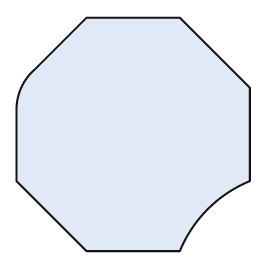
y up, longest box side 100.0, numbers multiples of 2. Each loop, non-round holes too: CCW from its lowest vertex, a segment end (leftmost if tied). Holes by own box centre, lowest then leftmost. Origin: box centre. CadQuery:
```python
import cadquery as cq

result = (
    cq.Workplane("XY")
    .moveTo(-20.0, -50.0)
    .lineTo(20.0, -50.0)
    .threePointArc((32.0, -32.0), (50.0, -20.0))
    .lineTo(50.0, 20.0)
    .lineTo(20.0, 50.0)
    .lineTo(-20.0, 50.0)
    .lineTo(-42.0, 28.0)
    .threePointArc((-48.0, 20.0), (-50.0, 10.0))
    .lineTo(-50.0, -20.0)
    .close()
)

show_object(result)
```